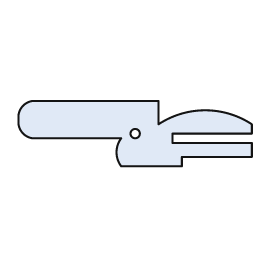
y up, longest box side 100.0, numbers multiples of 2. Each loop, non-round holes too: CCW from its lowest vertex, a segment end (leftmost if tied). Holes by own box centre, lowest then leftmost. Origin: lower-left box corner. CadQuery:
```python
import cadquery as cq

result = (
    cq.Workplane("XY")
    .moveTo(44.0, 0.0)
    .lineTo(70.0, 0.0)
    .lineTo(70.0, 4.0)
    .lineTo(100.0, 4.0)
    .lineTo(100.0, 10.0)
    .lineTo(66.0, 10.0)
    .lineTo(66.0, 14.0)
    .lineTo(100.0, 14.0)
    .lineTo(100.0, 18.0)
    .threePointArc((80.0, 24.0), (60.0, 18.0))
    .lineTo(60.0, 28.0)
    .lineTo(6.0, 28.0)
    .threePointArc((2.0, 26.0), (0.0, 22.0))
    .lineTo(0.0, 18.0)
    .threePointArc((2.0, 14.0), (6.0, 12.0))
    .lineTo(44.0, 12.0)
    .threePointArc((42.0, 6.0), (44.0, 0.0))
    .close()
    .moveTo(50.0, 14.0)
    .circle(2.0)
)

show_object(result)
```